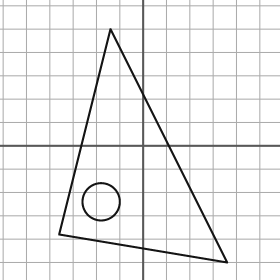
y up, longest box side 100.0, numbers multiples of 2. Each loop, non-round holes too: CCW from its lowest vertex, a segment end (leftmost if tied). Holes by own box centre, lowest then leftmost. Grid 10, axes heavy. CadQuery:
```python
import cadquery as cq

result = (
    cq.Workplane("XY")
    .moveTo(36.0, -50.0)
    .lineTo(-14.0, 50.0)
    .lineTo(-36.0, -38.0)
    .close()
    .moveTo(-18.0, -24.0)
    .circle(8.0)
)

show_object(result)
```